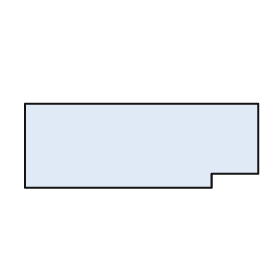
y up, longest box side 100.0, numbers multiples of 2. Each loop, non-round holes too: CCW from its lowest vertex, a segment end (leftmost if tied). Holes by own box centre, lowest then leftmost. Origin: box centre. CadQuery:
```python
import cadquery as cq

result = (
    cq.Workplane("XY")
    .moveTo(-50.0, -18.0)
    .lineTo(30.0, -18.0)
    .lineTo(30.0, -12.0)
    .lineTo(50.0, -12.0)
    .lineTo(50.0, 18.0)
    .lineTo(-50.0, 18.0)
    .close()
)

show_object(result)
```